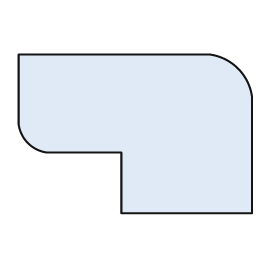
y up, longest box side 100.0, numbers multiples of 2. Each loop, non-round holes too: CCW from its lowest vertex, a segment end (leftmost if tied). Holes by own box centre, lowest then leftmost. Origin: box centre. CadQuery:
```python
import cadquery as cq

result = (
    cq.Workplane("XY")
    .moveTo(-6.0, -34.0)
    .lineTo(50.0, -34.0)
    .lineTo(50.0, 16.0)
    .threePointArc((44.0, 28.0), (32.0, 34.0))
    .lineTo(-50.0, 34.0)
    .lineTo(-50.0, 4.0)
    .threePointArc((-46.0, -4.0), (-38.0, -8.0))
    .lineTo(-6.0, -8.0)
    .close()
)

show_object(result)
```